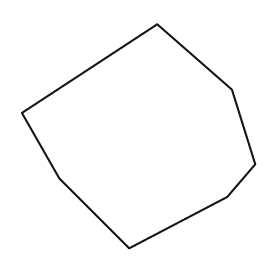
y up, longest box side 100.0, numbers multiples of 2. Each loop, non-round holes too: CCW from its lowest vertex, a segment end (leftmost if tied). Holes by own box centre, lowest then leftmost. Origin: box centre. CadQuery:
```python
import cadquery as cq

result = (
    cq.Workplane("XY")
    .moveTo(-4.0, -48.0)
    .lineTo(38.0, -26.0)
    .lineTo(50.0, -12.0)
    .lineTo(40.0, 20.0)
    .lineTo(8.0, 48.0)
    .lineTo(-50.0, 10.0)
    .lineTo(-34.0, -18.0)
    .close()
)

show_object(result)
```